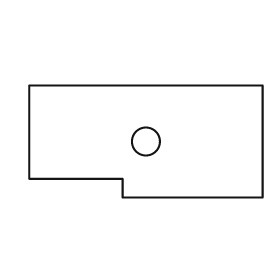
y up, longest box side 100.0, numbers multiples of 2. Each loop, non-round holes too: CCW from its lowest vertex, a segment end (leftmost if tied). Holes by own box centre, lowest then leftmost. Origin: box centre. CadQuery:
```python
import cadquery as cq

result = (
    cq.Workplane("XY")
    .moveTo(-10.0, -24.0)
    .lineTo(50.0, -24.0)
    .lineTo(50.0, 24.0)
    .lineTo(-50.0, 24.0)
    .lineTo(-50.0, -16.0)
    .lineTo(-10.0, -16.0)
    .close()
    .moveTo(0.0, 0.0)
    .circle(6.0)
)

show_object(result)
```